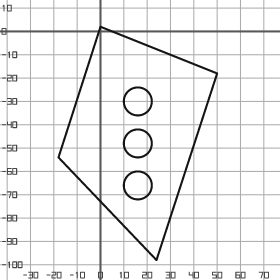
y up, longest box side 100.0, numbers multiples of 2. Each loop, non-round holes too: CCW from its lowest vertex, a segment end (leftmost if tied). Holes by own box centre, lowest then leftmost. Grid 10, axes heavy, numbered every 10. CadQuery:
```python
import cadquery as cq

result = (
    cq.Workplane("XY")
    .moveTo(24.0, -98.0)
    .lineTo(50.0, -18.0)
    .lineTo(0.0, 2.0)
    .lineTo(-18.0, -54.0)
    .close()
    .moveTo(16.0, -66.0)
    .circle(6.0)
    .moveTo(16.0, -48.0)
    .circle(6.0)
    .moveTo(16.0, -30.0)
    .circle(6.0)
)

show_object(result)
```